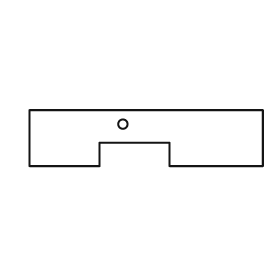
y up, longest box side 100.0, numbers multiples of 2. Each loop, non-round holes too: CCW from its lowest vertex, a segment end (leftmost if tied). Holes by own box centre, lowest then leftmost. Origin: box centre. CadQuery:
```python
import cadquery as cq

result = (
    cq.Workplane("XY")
    .moveTo(-50.0, -12.0)
    .lineTo(-20.0, -12.0)
    .lineTo(-20.0, -2.0)
    .lineTo(10.0, -2.0)
    .lineTo(10.0, -12.0)
    .lineTo(50.0, -12.0)
    .lineTo(50.0, 12.0)
    .lineTo(-50.0, 12.0)
    .close()
    .moveTo(-10.0, 6.0)
    .circle(2.0)
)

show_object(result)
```